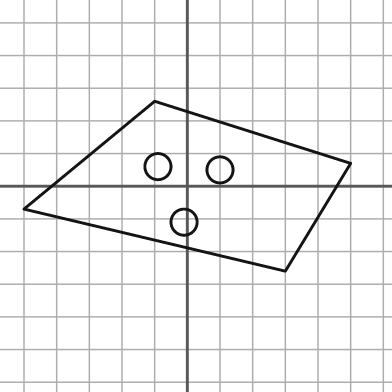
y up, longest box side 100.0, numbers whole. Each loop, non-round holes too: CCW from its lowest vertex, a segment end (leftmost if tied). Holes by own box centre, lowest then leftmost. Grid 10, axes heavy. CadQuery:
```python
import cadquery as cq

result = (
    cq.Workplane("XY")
    .moveTo(30.0, -26.0)
    .lineTo(50.0, 7.0)
    .lineTo(-10.0, 26.0)
    .lineTo(-50.0, -7.0)
    .close()
    .moveTo(-1.0, -11.0)
    .circle(4.0)
    .moveTo(10.0, 5.0)
    .circle(4.0)
    .moveTo(-9.0, 6.0)
    .circle(4.0)
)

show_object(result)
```